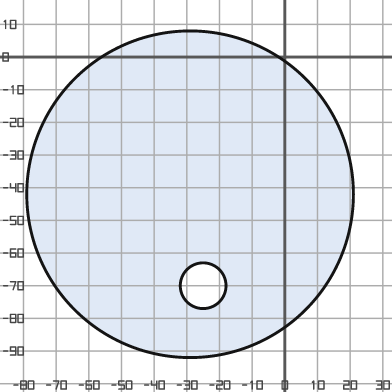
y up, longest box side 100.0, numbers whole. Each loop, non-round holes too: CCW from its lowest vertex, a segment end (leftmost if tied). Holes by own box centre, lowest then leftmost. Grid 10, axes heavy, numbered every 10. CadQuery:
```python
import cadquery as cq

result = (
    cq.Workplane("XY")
    .moveTo(-29.0, -42.0)
    .circle(50.0)
    .moveTo(-25.0, -70.0)
    .circle(7.0)
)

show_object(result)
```